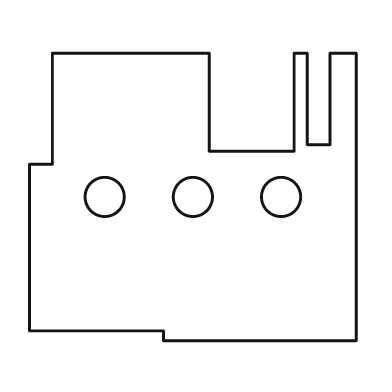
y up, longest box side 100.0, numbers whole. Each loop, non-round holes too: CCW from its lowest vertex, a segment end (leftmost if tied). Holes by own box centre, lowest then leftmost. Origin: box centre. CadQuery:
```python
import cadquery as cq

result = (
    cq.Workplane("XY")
    .moveTo(-9.0, -44.0)
    .lineTo(50.0, -44.0)
    .lineTo(50.0, 44.0)
    .lineTo(42.0, 44.0)
    .lineTo(42.0, 16.0)
    .lineTo(35.0, 16.0)
    .lineTo(35.0, 44.0)
    .lineTo(31.0, 44.0)
    .lineTo(31.0, 14.0)
    .lineTo(5.0, 14.0)
    .lineTo(5.0, 44.0)
    .lineTo(-43.0, 44.0)
    .lineTo(-43.0, 10.0)
    .lineTo(-50.0, 10.0)
    .lineTo(-50.0, -41.0)
    .lineTo(-9.0, -41.0)
    .close()
    .moveTo(-27.0, 0.0)
    .circle(6.0)
    .moveTo(0.0, 0.0)
    .circle(6.0)
    .moveTo(27.0, 0.0)
    .circle(6.0)
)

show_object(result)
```